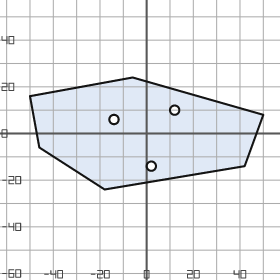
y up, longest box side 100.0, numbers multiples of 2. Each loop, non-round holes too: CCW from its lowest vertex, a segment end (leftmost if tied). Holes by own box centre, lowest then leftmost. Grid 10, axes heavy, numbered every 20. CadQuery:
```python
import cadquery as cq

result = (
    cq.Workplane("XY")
    .moveTo(-18.0, -24.0)
    .lineTo(42.0, -14.0)
    .lineTo(50.0, 8.0)
    .lineTo(-6.0, 24.0)
    .lineTo(-50.0, 16.0)
    .lineTo(-46.0, -6.0)
    .close()
    .moveTo(2.0, -14.0)
    .circle(2.0)
    .moveTo(-14.0, 6.0)
    .circle(2.0)
    .moveTo(12.0, 10.0)
    .circle(2.0)
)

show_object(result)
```